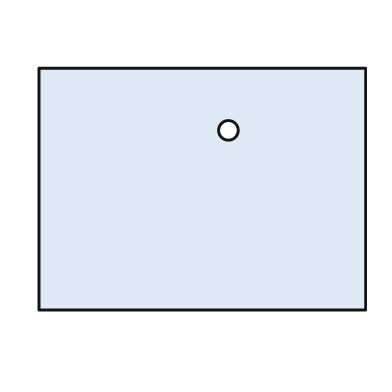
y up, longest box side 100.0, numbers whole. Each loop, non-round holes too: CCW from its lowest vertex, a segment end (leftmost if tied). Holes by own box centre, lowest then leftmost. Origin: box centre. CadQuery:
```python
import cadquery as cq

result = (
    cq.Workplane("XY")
    .moveTo(-50.0, -37.0)
    .lineTo(50.0, -37.0)
    .lineTo(50.0, 37.0)
    .lineTo(-50.0, 37.0)
    .close()
    .moveTo(8.0, 18.0)
    .circle(3.0)
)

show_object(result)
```